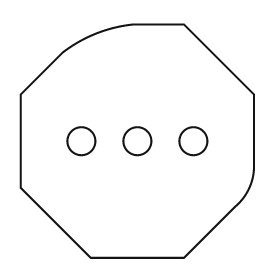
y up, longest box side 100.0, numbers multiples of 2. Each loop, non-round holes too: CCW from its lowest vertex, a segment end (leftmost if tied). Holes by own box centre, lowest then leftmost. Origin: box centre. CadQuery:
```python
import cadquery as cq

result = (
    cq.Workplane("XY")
    .moveTo(-20.0, -50.0)
    .lineTo(20.0, -50.0)
    .lineTo(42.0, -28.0)
    .threePointArc((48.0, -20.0), (50.0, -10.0))
    .lineTo(50.0, 20.0)
    .lineTo(20.0, 50.0)
    .lineTo(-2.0, 50.0)
    .threePointArc((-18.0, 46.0), (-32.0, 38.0))
    .lineTo(-50.0, 20.0)
    .lineTo(-50.0, -20.0)
    .close()
    .moveTo(-24.0, 0.0)
    .circle(6.0)
    .moveTo(0.0, 0.0)
    .circle(6.0)
    .moveTo(24.0, 0.0)
    .circle(6.0)
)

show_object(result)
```